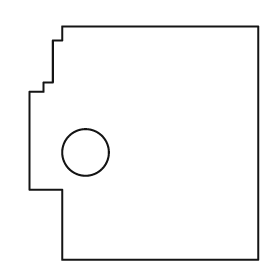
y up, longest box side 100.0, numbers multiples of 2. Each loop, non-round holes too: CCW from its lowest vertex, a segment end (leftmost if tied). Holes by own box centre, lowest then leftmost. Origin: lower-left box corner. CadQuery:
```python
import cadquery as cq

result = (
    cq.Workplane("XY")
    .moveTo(14.0, 0.0)
    .lineTo(98.0, 0.0)
    .lineTo(98.0, 100.0)
    .lineTo(14.0, 100.0)
    .lineTo(14.0, 94.0)
    .lineTo(10.0, 94.0)
    .lineTo(10.0, 76.0)
    .lineTo(6.0, 76.0)
    .lineTo(6.0, 72.0)
    .lineTo(0.0, 72.0)
    .lineTo(0.0, 30.0)
    .lineTo(14.0, 30.0)
    .close()
    .moveTo(24.0, 46.0)
    .circle(10.0)
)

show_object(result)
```